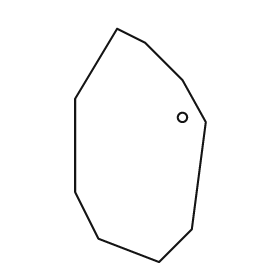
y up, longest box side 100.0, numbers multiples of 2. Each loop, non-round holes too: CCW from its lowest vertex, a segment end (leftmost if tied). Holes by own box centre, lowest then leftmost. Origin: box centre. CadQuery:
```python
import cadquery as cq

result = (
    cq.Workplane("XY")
    .moveTo(8.0, -50.0)
    .lineTo(22.0, -36.0)
    .lineTo(28.0, 10.0)
    .lineTo(18.0, 28.0)
    .lineTo(2.0, 44.0)
    .lineTo(-10.0, 50.0)
    .lineTo(-28.0, 20.0)
    .lineTo(-28.0, -20.0)
    .lineTo(-18.0, -40.0)
    .close()
    .moveTo(18.0, 12.0)
    .circle(2.0)
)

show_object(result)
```